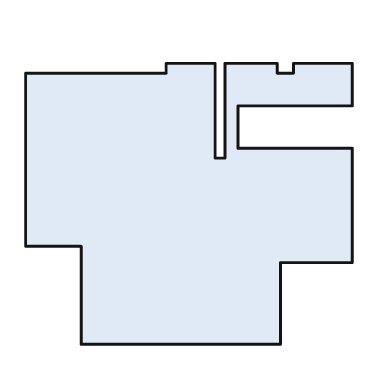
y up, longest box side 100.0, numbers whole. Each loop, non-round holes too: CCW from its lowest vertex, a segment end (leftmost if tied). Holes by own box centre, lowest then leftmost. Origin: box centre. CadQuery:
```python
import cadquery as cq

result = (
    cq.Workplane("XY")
    .moveTo(-33.0, -43.0)
    .lineTo(28.0, -43.0)
    .lineTo(28.0, -18.0)
    .lineTo(50.0, -18.0)
    .lineTo(50.0, 17.0)
    .lineTo(15.0, 17.0)
    .lineTo(15.0, 30.0)
    .lineTo(50.0, 30.0)
    .lineTo(50.0, 43.0)
    .lineTo(32.0, 43.0)
    .lineTo(32.0, 40.0)
    .lineTo(27.0, 40.0)
    .lineTo(27.0, 43.0)
    .lineTo(11.0, 43.0)
    .lineTo(11.0, 14.0)
    .lineTo(8.0, 14.0)
    .lineTo(8.0, 43.0)
    .lineTo(-7.0, 43.0)
    .lineTo(-7.0, 40.0)
    .lineTo(-50.0, 40.0)
    .lineTo(-50.0, -13.0)
    .lineTo(-33.0, -13.0)
    .close()
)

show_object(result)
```